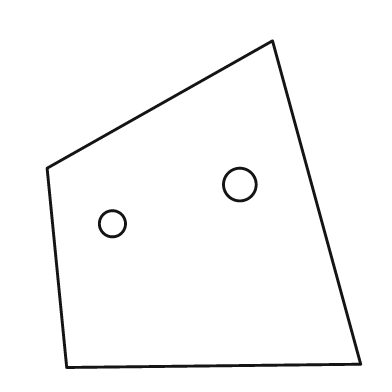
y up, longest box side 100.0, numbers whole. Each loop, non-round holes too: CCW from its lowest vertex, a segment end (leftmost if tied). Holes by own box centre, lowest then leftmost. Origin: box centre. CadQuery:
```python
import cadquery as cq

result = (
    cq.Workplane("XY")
    .moveTo(-42.0, -50.0)
    .lineTo(48.0, -49.0)
    .lineTo(21.0, 50.0)
    .lineTo(-48.0, 11.0)
    .close()
    .moveTo(-28.0, -6.0)
    .circle(4.0)
    .moveTo(11.0, 6.0)
    .circle(5.0)
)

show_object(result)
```